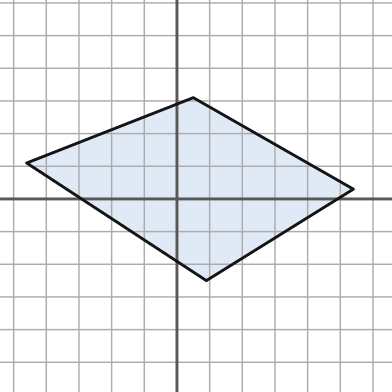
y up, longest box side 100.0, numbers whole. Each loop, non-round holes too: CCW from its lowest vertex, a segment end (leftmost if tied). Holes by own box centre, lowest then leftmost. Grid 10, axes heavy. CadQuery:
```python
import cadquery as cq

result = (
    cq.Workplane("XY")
    .moveTo(9.0, -25.0)
    .lineTo(54.0, 3.0)
    .lineTo(5.0, 31.0)
    .lineTo(-46.0, 11.0)
    .close()
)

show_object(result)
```